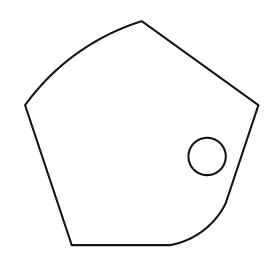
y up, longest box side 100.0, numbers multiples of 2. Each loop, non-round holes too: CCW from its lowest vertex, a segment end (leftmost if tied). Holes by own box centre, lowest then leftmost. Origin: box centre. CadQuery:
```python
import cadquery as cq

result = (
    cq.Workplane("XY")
    .moveTo(-30.0, -48.0)
    .lineTo(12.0, -48.0)
    .threePointArc((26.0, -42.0), (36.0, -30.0))
    .lineTo(50.0, 12.0)
    .lineTo(0.0, 48.0)
    .threePointArc((-28.0, 34.0), (-50.0, 12.0))
    .close()
    .moveTo(28.0, -10.0)
    .circle(8.0)
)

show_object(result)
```